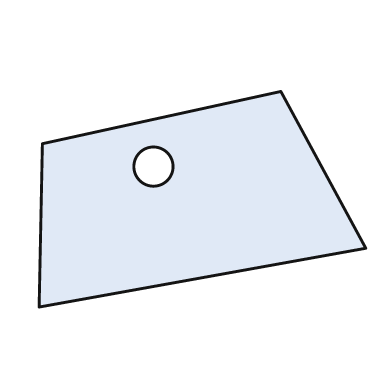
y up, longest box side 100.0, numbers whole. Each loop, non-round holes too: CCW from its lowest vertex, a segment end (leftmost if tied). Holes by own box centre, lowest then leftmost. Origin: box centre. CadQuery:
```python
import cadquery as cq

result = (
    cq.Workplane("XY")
    .moveTo(-50.0, -33.0)
    .lineTo(50.0, -15.0)
    .lineTo(24.0, 33.0)
    .lineTo(-49.0, 17.0)
    .close()
    .moveTo(-15.0, 10.0)
    .circle(6.0)
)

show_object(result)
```